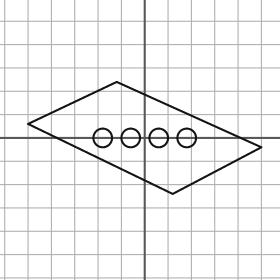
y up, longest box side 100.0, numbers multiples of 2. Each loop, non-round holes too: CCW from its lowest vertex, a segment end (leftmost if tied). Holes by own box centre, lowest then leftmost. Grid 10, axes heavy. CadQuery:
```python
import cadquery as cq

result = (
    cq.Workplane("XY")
    .moveTo(12.0, -24.0)
    .lineTo(50.0, -4.0)
    .lineTo(-12.0, 24.0)
    .lineTo(-50.0, 6.0)
    .close()
    .moveTo(-18.0, 0.0)
    .circle(4.0)
    .moveTo(-6.0, 0.0)
    .circle(4.0)
    .moveTo(6.0, 0.0)
    .circle(4.0)
    .moveTo(18.0, 0.0)
    .circle(4.0)
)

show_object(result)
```